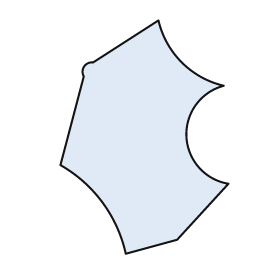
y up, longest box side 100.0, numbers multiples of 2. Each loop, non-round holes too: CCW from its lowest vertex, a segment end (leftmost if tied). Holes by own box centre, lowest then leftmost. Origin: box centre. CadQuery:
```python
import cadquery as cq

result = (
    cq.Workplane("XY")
    .moveTo(-8.0, -50.0)
    .lineTo(14.0, -44.0)
    .lineTo(36.0, -20.0)
    .threePointArc((18.0, 0.0), (34.0, 22.0))
    .threePointArc((16.0, 32.0), (6.0, 50.0))
    .lineTo(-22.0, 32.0)
    .threePointArc((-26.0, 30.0), (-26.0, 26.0))
    .lineTo(-36.0, -12.0)
    .threePointArc((-18.0, -28.0), (-8.0, -50.0))
    .close()
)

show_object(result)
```